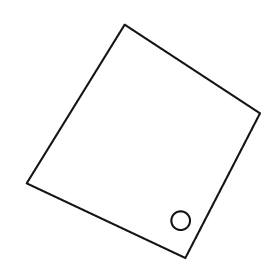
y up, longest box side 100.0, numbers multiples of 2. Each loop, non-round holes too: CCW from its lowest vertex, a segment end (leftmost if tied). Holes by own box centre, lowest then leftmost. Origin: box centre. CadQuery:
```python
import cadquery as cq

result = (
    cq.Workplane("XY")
    .moveTo(18.0, -50.0)
    .lineTo(50.0, 12.0)
    .lineTo(-8.0, 50.0)
    .lineTo(-50.0, -18.0)
    .close()
    .moveTo(16.0, -34.0)
    .circle(4.0)
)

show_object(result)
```